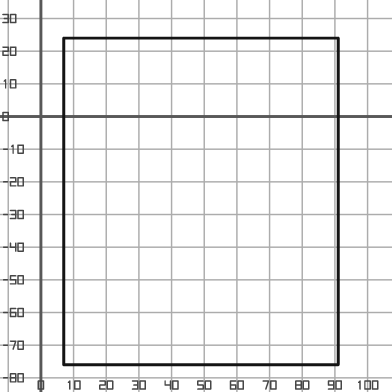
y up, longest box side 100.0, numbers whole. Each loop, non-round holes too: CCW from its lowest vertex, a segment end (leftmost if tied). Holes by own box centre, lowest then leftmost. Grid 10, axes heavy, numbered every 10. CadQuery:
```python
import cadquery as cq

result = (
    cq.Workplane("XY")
    .moveTo(7.0, -76.0)
    .lineTo(91.0, -76.0)
    .lineTo(91.0, 24.0)
    .lineTo(7.0, 24.0)
    .close()
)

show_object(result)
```